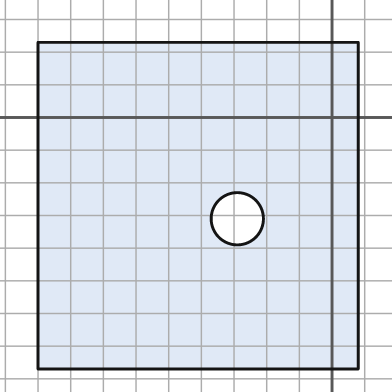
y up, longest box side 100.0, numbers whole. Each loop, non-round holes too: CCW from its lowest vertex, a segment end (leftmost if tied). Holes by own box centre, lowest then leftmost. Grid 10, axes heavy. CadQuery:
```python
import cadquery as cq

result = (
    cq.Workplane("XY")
    .moveTo(-90.0, -77.0)
    .lineTo(8.0, -77.0)
    .lineTo(8.0, 23.0)
    .lineTo(-90.0, 23.0)
    .close()
    .moveTo(-29.0, -31.0)
    .circle(8.0)
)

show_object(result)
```